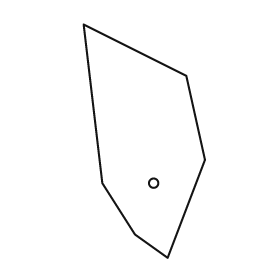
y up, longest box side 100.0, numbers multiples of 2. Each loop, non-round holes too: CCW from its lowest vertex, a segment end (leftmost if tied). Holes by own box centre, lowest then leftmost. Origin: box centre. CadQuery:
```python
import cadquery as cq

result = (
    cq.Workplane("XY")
    .moveTo(10.0, -50.0)
    .lineTo(26.0, -8.0)
    .lineTo(18.0, 28.0)
    .lineTo(-26.0, 50.0)
    .lineTo(-18.0, -18.0)
    .lineTo(-4.0, -40.0)
    .close()
    .moveTo(4.0, -18.0)
    .circle(2.0)
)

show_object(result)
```